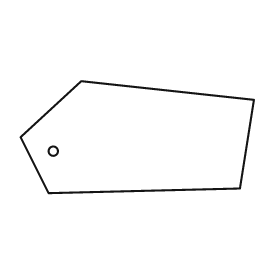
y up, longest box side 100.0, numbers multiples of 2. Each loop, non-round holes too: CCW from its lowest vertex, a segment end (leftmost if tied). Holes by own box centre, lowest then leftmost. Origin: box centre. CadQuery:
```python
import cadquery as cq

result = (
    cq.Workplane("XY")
    .moveTo(-38.0, -24.0)
    .lineTo(44.0, -22.0)
    .lineTo(50.0, 16.0)
    .lineTo(-24.0, 24.0)
    .lineTo(-50.0, 0.0)
    .close()
    .moveTo(-36.0, -6.0)
    .circle(2.0)
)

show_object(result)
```